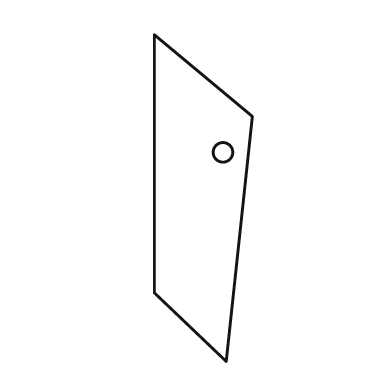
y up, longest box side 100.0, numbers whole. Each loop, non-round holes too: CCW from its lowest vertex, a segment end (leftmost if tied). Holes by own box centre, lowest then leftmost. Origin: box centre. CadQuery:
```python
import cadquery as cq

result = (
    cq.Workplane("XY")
    .moveTo(7.0, -50.0)
    .lineTo(15.0, 25.0)
    .lineTo(-15.0, 50.0)
    .lineTo(-15.0, -29.0)
    .close()
    .moveTo(6.0, 14.0)
    .circle(3.0)
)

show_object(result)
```